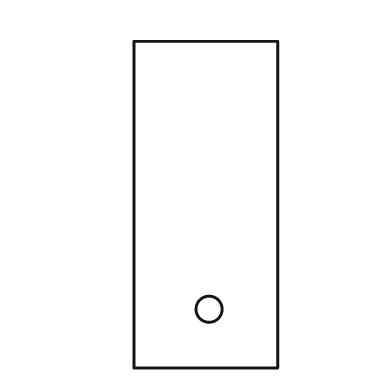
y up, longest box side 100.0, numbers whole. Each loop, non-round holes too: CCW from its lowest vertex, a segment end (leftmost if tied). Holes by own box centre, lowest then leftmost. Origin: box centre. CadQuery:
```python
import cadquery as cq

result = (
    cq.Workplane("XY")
    .moveTo(-22.0, -50.0)
    .lineTo(22.0, -50.0)
    .lineTo(22.0, 50.0)
    .lineTo(-22.0, 50.0)
    .close()
    .moveTo(1.0, -32.0)
    .circle(4.0)
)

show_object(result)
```